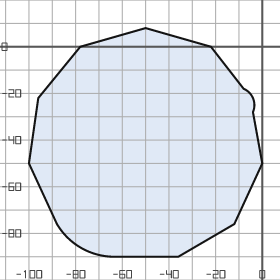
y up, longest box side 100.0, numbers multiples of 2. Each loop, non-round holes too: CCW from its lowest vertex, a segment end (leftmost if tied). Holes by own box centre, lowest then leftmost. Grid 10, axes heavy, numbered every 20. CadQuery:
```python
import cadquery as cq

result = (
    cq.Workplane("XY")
    .moveTo(-64.0, -90.0)
    .lineTo(-36.0, -90.0)
    .lineTo(-12.0, -76.0)
    .lineTo(0.0, -50.0)
    .lineTo(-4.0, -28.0)
    .threePointArc((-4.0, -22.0), (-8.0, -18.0))
    .lineTo(-22.0, 0.0)
    .lineTo(-50.0, 8.0)
    .lineTo(-78.0, 0.0)
    .lineTo(-96.0, -22.0)
    .lineTo(-100.0, -50.0)
    .lineTo(-88.0, -76.0)
    .threePointArc((-78.0, -86.0), (-64.0, -90.0))
    .close()
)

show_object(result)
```